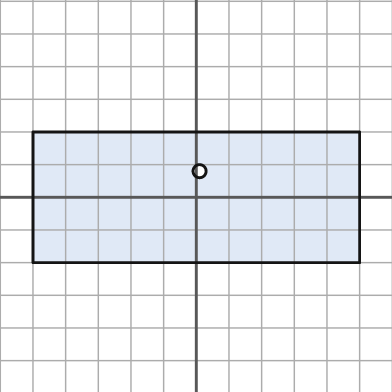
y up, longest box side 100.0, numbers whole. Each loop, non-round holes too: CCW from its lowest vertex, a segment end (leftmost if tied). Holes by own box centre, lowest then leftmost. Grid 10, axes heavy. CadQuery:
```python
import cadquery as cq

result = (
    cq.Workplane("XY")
    .moveTo(-50.0, -20.0)
    .lineTo(50.0, -20.0)
    .lineTo(50.0, 20.0)
    .lineTo(-50.0, 20.0)
    .close()
    .moveTo(1.0, 8.0)
    .circle(2.0)
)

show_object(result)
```